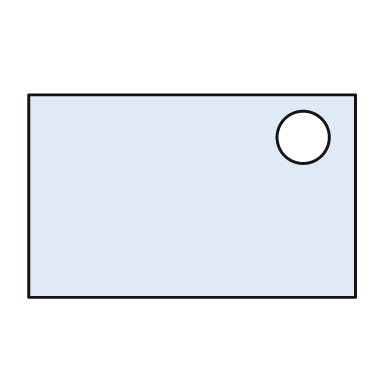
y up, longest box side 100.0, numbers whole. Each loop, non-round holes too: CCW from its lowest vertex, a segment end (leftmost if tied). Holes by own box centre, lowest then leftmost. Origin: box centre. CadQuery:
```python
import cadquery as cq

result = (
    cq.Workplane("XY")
    .moveTo(-50.0, -31.0)
    .lineTo(50.0, -31.0)
    .lineTo(50.0, 31.0)
    .lineTo(-50.0, 31.0)
    .close()
    .moveTo(34.0, 18.0)
    .circle(8.0)
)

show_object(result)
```